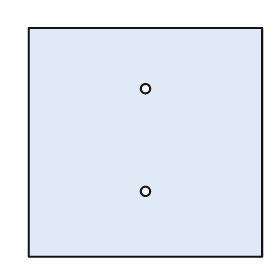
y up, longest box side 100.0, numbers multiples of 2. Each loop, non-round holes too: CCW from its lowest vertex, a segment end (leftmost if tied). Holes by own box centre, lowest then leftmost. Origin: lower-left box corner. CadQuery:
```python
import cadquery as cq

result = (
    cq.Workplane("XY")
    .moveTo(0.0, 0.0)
    .lineTo(100.0, 0.0)
    .lineTo(100.0, 98.0)
    .lineTo(0.0, 98.0)
    .close()
    .moveTo(50.0, 28.0)
    .circle(2.0)
    .moveTo(50.0, 72.0)
    .circle(2.0)
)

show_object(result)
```